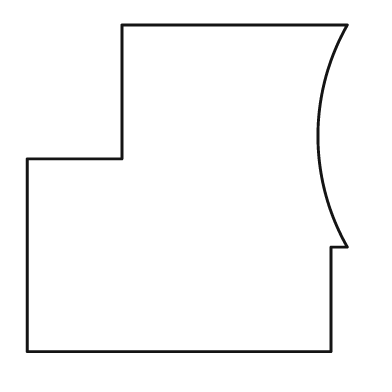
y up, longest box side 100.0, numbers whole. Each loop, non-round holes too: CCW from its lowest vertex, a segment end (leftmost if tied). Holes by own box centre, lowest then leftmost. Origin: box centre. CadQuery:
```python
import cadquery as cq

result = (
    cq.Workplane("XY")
    .moveTo(-49.0, -50.0)
    .lineTo(44.0, -50.0)
    .lineTo(44.0, -18.0)
    .lineTo(49.0, -18.0)
    .threePointArc((40.0, 16.0), (49.0, 50.0))
    .lineTo(-20.0, 50.0)
    .lineTo(-20.0, 9.0)
    .lineTo(-49.0, 9.0)
    .close()
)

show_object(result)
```